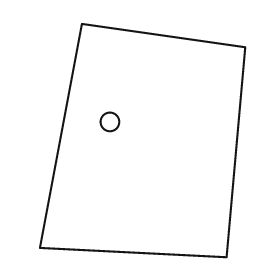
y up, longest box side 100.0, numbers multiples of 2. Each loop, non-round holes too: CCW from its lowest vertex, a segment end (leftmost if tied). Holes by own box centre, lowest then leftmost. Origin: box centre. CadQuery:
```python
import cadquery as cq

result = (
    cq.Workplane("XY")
    .moveTo(36.0, -50.0)
    .lineTo(44.0, 40.0)
    .lineTo(-26.0, 50.0)
    .lineTo(-44.0, -46.0)
    .close()
    .moveTo(-14.0, 8.0)
    .circle(4.0)
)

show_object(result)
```